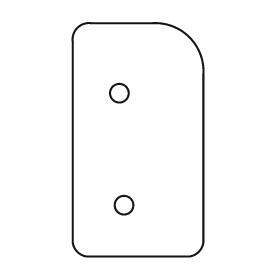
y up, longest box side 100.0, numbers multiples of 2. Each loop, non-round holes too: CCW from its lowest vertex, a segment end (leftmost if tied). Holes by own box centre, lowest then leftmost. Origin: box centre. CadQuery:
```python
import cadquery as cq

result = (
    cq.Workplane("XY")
    .moveTo(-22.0, -50.0)
    .lineTo(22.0, -50.0)
    .threePointArc((26.0, -48.0), (28.0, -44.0))
    .lineTo(28.0, 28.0)
    .threePointArc((22.0, 44.0), (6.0, 50.0))
    .lineTo(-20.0, 50.0)
    .threePointArc((-26.0, 48.0), (-28.0, 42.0))
    .lineTo(-28.0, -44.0)
    .threePointArc((-26.0, -48.0), (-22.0, -50.0))
    .close()
    .moveTo(-6.0, -28.0)
    .circle(4.0)
    .moveTo(-8.0, 20.0)
    .circle(4.0)
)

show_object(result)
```